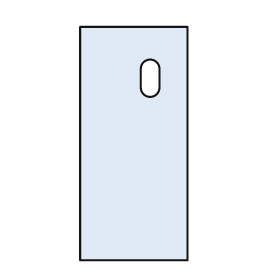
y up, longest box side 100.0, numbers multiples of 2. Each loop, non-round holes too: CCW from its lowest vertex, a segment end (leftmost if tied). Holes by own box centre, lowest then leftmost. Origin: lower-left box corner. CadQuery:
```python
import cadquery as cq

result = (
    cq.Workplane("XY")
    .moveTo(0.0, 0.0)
    .lineTo(46.0, 0.0)
    .lineTo(46.0, 100.0)
    .lineTo(0.0, 100.0)
    .close()
    .moveTo(26.0, 74.0)
    .threePointArc((30.0, 70.0), (34.0, 74.0))
    .lineTo(34.0, 82.0)
    .threePointArc((30.0, 86.0), (26.0, 82.0))
    .close()
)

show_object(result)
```